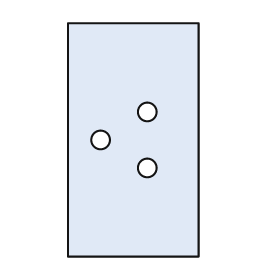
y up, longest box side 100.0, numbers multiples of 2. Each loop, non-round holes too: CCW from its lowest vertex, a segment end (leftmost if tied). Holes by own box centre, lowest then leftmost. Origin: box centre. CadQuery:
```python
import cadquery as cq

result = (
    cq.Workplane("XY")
    .moveTo(-28.0, -50.0)
    .lineTo(28.0, -50.0)
    .lineTo(28.0, 50.0)
    .lineTo(-28.0, 50.0)
    .close()
    .moveTo(6.0, -12.0)
    .circle(4.0)
    .moveTo(-14.0, 0.0)
    .circle(4.0)
    .moveTo(6.0, 12.0)
    .circle(4.0)
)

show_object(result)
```